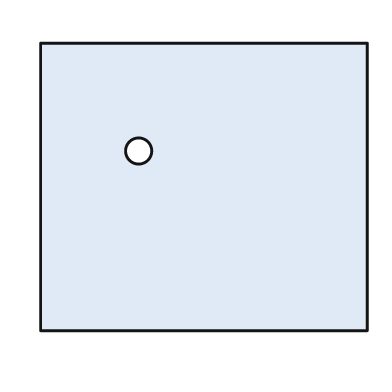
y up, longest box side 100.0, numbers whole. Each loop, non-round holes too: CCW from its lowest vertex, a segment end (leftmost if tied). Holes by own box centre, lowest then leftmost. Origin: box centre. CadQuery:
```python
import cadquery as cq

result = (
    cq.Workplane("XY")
    .moveTo(-50.0, -44.0)
    .lineTo(50.0, -44.0)
    .lineTo(50.0, 44.0)
    .lineTo(-50.0, 44.0)
    .close()
    .moveTo(-20.0, 11.0)
    .circle(4.0)
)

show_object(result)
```